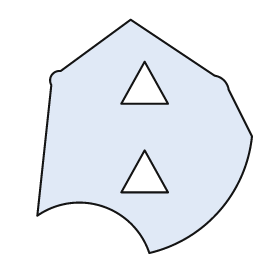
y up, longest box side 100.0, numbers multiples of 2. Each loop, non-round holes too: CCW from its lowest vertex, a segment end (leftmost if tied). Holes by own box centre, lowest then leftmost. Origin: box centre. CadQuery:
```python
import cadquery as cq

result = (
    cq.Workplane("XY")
    .moveTo(2.0, -50.0)
    .threePointArc((32.0, -32.0), (46.0, 0.0))
    .lineTo(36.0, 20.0)
    .threePointArc((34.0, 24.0), (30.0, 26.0))
    .lineTo(-6.0, 50.0)
    .lineTo(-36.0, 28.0)
    .threePointArc((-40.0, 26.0), (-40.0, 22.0))
    .lineTo(-46.0, -34.0)
    .threePointArc((-18.0, -30.0), (2.0, -50.0))
    .close()
    .moveTo(-10.0, -24.0)
    .lineTo(10.0, -24.0)
    .lineTo(0.0, -6.0)
    .close()
    .moveTo(-10.0, 14.0)
    .lineTo(10.0, 14.0)
    .lineTo(0.0, 32.0)
    .close()
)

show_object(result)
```